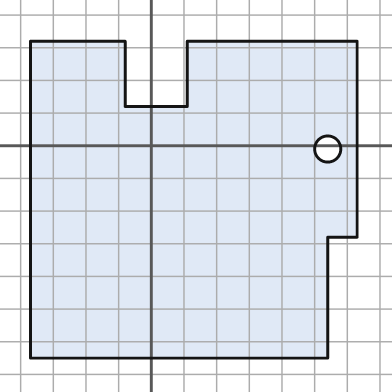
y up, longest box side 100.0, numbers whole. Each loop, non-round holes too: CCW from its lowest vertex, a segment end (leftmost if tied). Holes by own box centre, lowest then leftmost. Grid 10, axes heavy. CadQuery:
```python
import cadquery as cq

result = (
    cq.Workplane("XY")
    .moveTo(-37.0, -65.0)
    .lineTo(54.0, -65.0)
    .lineTo(54.0, -28.0)
    .lineTo(63.0, -28.0)
    .lineTo(63.0, 32.0)
    .lineTo(11.0, 32.0)
    .lineTo(11.0, 12.0)
    .lineTo(-8.0, 12.0)
    .lineTo(-8.0, 32.0)
    .lineTo(-37.0, 32.0)
    .close()
    .moveTo(54.0, -1.0)
    .circle(4.0)
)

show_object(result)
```